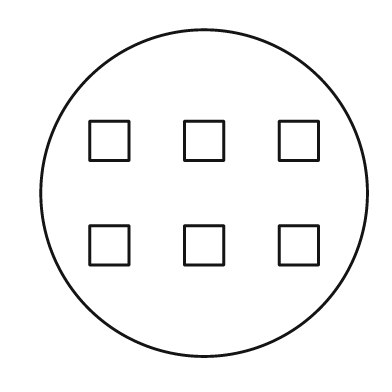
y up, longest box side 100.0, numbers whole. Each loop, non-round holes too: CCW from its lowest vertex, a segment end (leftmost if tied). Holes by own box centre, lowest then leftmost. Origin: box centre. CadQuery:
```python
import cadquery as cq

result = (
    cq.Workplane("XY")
    .moveTo(0.0, 0.0)
    .circle(50.0)
    .moveTo(-35.0, -22.0)
    .lineTo(-23.0, -22.0)
    .lineTo(-23.0, -10.0)
    .lineTo(-35.0, -10.0)
    .close()
    .moveTo(-6.0, -22.0)
    .lineTo(6.0, -22.0)
    .lineTo(6.0, -10.0)
    .lineTo(-6.0, -10.0)
    .close()
    .moveTo(23.0, -22.0)
    .lineTo(35.0, -22.0)
    .lineTo(35.0, -10.0)
    .lineTo(23.0, -10.0)
    .close()
    .moveTo(-35.0, 10.0)
    .lineTo(-23.0, 10.0)
    .lineTo(-23.0, 22.0)
    .lineTo(-35.0, 22.0)
    .close()
    .moveTo(-6.0, 10.0)
    .lineTo(6.0, 10.0)
    .lineTo(6.0, 22.0)
    .lineTo(-6.0, 22.0)
    .close()
    .moveTo(23.0, 10.0)
    .lineTo(35.0, 10.0)
    .lineTo(35.0, 22.0)
    .lineTo(23.0, 22.0)
    .close()
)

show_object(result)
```